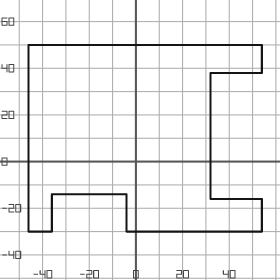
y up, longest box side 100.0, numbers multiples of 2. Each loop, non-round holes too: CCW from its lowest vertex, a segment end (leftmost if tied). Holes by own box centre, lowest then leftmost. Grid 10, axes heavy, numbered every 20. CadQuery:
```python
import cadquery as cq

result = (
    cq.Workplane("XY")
    .moveTo(-46.0, -30.0)
    .lineTo(-36.0, -30.0)
    .lineTo(-36.0, -14.0)
    .lineTo(-4.0, -14.0)
    .lineTo(-4.0, -30.0)
    .lineTo(54.0, -30.0)
    .lineTo(54.0, -16.0)
    .lineTo(32.0, -16.0)
    .lineTo(32.0, 38.0)
    .lineTo(54.0, 38.0)
    .lineTo(54.0, 50.0)
    .lineTo(-46.0, 50.0)
    .close()
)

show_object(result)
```